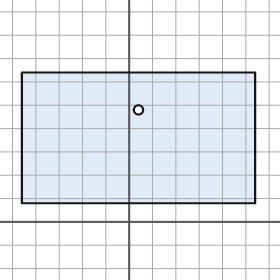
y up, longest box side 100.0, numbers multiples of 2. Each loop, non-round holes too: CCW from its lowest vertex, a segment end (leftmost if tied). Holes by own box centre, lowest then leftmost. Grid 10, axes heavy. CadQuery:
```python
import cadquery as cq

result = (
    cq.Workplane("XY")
    .moveTo(-46.0, 8.0)
    .lineTo(54.0, 8.0)
    .lineTo(54.0, 64.0)
    .lineTo(-46.0, 64.0)
    .close()
    .moveTo(4.0, 48.0)
    .circle(2.0)
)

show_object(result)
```